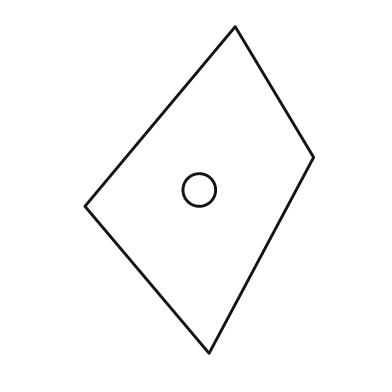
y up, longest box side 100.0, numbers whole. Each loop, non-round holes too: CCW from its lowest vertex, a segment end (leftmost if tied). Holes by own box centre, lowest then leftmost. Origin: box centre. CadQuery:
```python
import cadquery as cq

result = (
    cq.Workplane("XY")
    .moveTo(3.0, -50.0)
    .lineTo(35.0, 10.0)
    .lineTo(11.0, 50.0)
    .lineTo(-35.0, -5.0)
    .close()
    .moveTo(0.0, 0.0)
    .circle(5.0)
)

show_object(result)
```